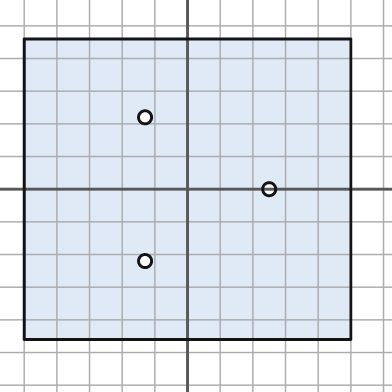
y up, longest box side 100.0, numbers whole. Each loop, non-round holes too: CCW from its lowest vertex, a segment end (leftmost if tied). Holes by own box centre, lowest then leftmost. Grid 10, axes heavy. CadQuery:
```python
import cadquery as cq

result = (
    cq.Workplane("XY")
    .moveTo(-50.0, -46.0)
    .lineTo(50.0, -46.0)
    .lineTo(50.0, 46.0)
    .lineTo(-50.0, 46.0)
    .close()
    .moveTo(-13.0, -22.0)
    .circle(2.0)
    .moveTo(25.0, 0.0)
    .circle(2.0)
    .moveTo(-13.0, 22.0)
    .circle(2.0)
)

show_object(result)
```